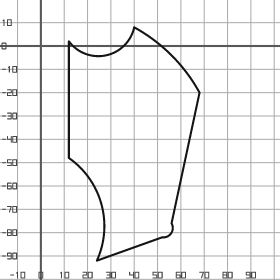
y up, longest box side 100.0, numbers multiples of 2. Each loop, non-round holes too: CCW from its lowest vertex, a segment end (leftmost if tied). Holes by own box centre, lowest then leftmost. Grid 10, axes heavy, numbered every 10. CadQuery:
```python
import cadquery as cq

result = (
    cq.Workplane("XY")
    .moveTo(24.0, -92.0)
    .lineTo(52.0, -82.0)
    .threePointArc((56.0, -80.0), (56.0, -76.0))
    .lineTo(68.0, -20.0)
    .threePointArc((56.0, -4.0), (40.0, 8.0))
    .threePointArc((28.0, -4.0), (12.0, 2.0))
    .lineTo(12.0, -48.0)
    .threePointArc((26.0, -68.0), (24.0, -92.0))
    .close()
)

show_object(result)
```